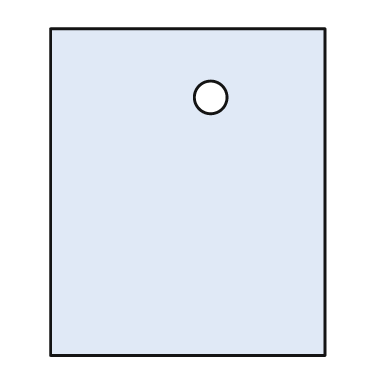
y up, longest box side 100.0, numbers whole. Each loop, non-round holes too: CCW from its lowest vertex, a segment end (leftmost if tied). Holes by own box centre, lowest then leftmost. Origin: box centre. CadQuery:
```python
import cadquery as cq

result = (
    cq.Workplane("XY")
    .moveTo(-42.0, -50.0)
    .lineTo(42.0, -50.0)
    .lineTo(42.0, 50.0)
    .lineTo(-42.0, 50.0)
    .close()
    .moveTo(7.0, 29.0)
    .circle(5.0)
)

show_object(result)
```